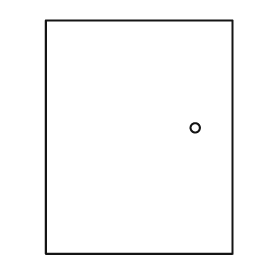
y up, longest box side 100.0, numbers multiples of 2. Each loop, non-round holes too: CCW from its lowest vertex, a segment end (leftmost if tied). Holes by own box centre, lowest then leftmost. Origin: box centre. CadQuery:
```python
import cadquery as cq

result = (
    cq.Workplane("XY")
    .moveTo(-40.0, -50.0)
    .lineTo(40.0, -50.0)
    .lineTo(40.0, 50.0)
    .lineTo(-40.0, 50.0)
    .close()
    .moveTo(24.0, 4.0)
    .circle(2.0)
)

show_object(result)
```